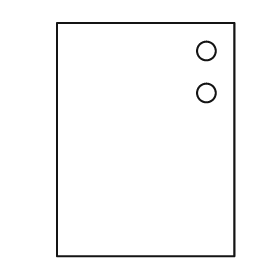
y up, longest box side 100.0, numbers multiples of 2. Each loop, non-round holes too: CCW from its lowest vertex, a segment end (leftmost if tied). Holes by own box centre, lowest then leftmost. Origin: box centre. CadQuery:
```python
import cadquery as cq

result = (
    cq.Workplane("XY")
    .moveTo(-38.0, -50.0)
    .lineTo(38.0, -50.0)
    .lineTo(38.0, 50.0)
    .lineTo(-38.0, 50.0)
    .close()
    .moveTo(26.0, 20.0)
    .circle(4.0)
    .moveTo(26.0, 38.0)
    .circle(4.0)
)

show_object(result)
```